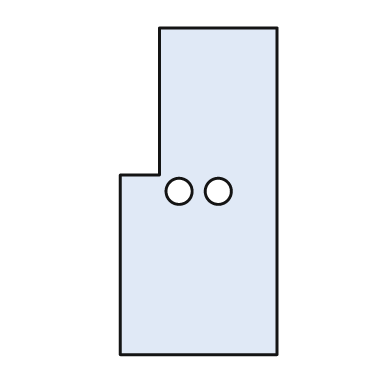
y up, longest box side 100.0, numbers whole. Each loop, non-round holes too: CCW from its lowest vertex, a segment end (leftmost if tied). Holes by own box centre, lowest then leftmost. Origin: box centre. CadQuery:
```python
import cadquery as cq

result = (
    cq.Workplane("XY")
    .moveTo(-24.0, -50.0)
    .lineTo(24.0, -50.0)
    .lineTo(24.0, 50.0)
    .lineTo(-12.0, 50.0)
    .lineTo(-12.0, 5.0)
    .lineTo(-24.0, 5.0)
    .close()
    .moveTo(-6.0, 0.0)
    .circle(4.0)
    .moveTo(6.0, 0.0)
    .circle(4.0)
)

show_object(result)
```